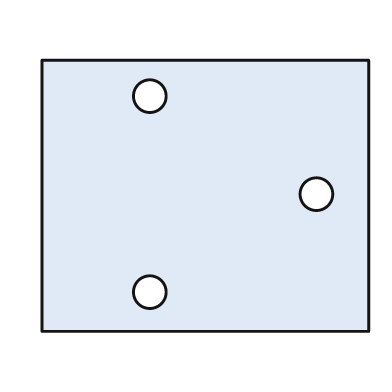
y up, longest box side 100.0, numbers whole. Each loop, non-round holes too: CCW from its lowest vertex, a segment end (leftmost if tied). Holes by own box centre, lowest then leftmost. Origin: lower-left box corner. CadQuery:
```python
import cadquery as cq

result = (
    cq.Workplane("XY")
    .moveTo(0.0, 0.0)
    .lineTo(100.0, 0.0)
    .lineTo(100.0, 83.0)
    .lineTo(0.0, 83.0)
    .close()
    .moveTo(33.0, 12.0)
    .circle(5.0)
    .moveTo(84.0, 42.0)
    .circle(5.0)
    .moveTo(33.0, 72.0)
    .circle(5.0)
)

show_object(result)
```